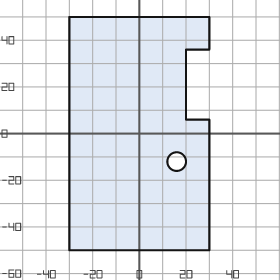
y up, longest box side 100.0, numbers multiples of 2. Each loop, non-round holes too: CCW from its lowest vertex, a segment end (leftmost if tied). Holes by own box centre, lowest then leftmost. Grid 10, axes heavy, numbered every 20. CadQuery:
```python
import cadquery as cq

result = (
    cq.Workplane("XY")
    .moveTo(-30.0, -50.0)
    .lineTo(30.0, -50.0)
    .lineTo(30.0, 6.0)
    .lineTo(20.0, 6.0)
    .lineTo(20.0, 36.0)
    .lineTo(30.0, 36.0)
    .lineTo(30.0, 50.0)
    .lineTo(-30.0, 50.0)
    .close()
    .moveTo(16.0, -12.0)
    .circle(4.0)
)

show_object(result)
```